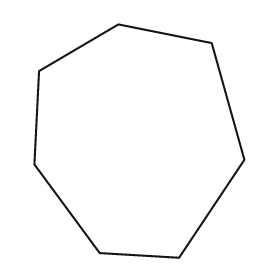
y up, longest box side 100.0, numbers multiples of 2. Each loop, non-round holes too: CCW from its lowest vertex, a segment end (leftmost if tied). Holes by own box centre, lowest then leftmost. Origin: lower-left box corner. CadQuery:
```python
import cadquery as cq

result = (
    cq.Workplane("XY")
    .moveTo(62.0, 0.0)
    .lineTo(90.0, 42.0)
    .lineTo(76.0, 92.0)
    .lineTo(36.0, 100.0)
    .lineTo(2.0, 80.0)
    .lineTo(0.0, 40.0)
    .lineTo(28.0, 2.0)
    .close()
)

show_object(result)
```